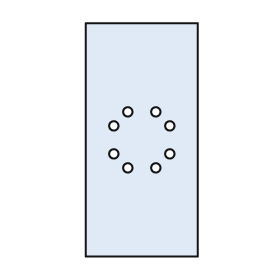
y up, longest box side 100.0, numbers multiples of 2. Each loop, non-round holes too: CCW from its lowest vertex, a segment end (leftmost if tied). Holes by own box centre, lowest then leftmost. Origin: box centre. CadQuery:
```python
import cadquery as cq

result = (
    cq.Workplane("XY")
    .moveTo(-24.0, -50.0)
    .lineTo(24.0, -50.0)
    .lineTo(24.0, 50.0)
    .lineTo(-24.0, 50.0)
    .close()
    .moveTo(-6.0, -12.0)
    .circle(2.0)
    .moveTo(6.0, -12.0)
    .circle(2.0)
    .moveTo(-12.0, -6.0)
    .circle(2.0)
    .moveTo(12.0, -6.0)
    .circle(2.0)
    .moveTo(-12.0, 6.0)
    .circle(2.0)
    .moveTo(12.0, 6.0)
    .circle(2.0)
    .moveTo(-6.0, 12.0)
    .circle(2.0)
    .moveTo(6.0, 12.0)
    .circle(2.0)
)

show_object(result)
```